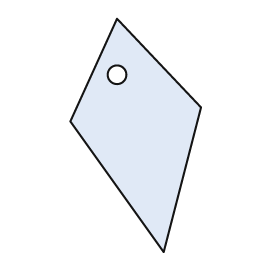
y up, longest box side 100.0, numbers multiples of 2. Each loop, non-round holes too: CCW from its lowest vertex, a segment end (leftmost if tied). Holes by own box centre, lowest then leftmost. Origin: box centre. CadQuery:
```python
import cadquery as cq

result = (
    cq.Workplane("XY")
    .moveTo(12.0, -50.0)
    .lineTo(28.0, 12.0)
    .lineTo(-8.0, 50.0)
    .lineTo(-28.0, 6.0)
    .close()
    .moveTo(-8.0, 26.0)
    .circle(4.0)
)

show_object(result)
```